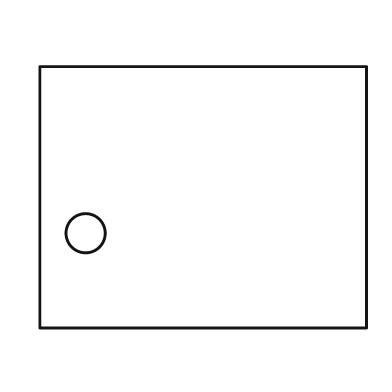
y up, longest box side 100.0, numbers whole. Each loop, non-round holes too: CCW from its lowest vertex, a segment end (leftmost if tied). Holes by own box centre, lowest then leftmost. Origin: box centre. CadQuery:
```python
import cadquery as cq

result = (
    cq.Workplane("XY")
    .moveTo(-50.0, -40.0)
    .lineTo(50.0, -40.0)
    .lineTo(50.0, 40.0)
    .lineTo(-50.0, 40.0)
    .close()
    .moveTo(-36.0, -11.0)
    .circle(6.0)
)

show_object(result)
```